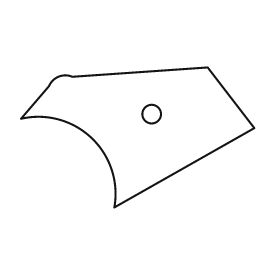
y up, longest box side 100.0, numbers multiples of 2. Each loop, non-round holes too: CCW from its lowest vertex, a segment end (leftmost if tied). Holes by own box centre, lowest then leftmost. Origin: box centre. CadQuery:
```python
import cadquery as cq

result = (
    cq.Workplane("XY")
    .moveTo(-10.0, -30.0)
    .lineTo(50.0, 4.0)
    .lineTo(30.0, 30.0)
    .lineTo(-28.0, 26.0)
    .threePointArc((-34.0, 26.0), (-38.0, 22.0))
    .lineTo(-50.0, 8.0)
    .threePointArc((-20.0, 0.0), (-10.0, -30.0))
    .close()
    .moveTo(6.0, 10.0)
    .circle(4.0)
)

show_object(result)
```